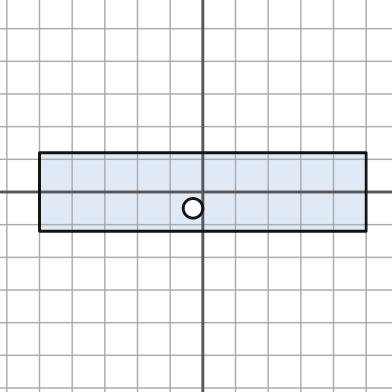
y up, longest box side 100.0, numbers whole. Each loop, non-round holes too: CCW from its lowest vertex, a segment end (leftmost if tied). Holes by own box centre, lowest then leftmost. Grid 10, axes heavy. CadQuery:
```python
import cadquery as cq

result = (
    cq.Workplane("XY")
    .moveTo(-50.0, -12.0)
    .lineTo(50.0, -12.0)
    .lineTo(50.0, 12.0)
    .lineTo(-50.0, 12.0)
    .close()
    .moveTo(-3.0, -5.0)
    .circle(3.0)
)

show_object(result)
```